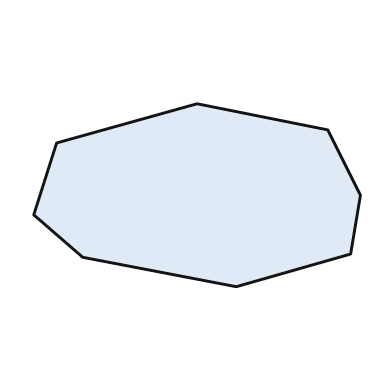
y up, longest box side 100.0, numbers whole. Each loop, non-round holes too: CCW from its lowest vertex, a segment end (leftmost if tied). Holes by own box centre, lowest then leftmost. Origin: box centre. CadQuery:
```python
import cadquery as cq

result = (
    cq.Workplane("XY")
    .moveTo(12.0, -28.0)
    .lineTo(47.0, -18.0)
    .lineTo(50.0, 0.0)
    .lineTo(40.0, 20.0)
    .lineTo(0.0, 28.0)
    .lineTo(-43.0, 16.0)
    .lineTo(-50.0, -6.0)
    .lineTo(-35.0, -19.0)
    .close()
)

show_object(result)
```